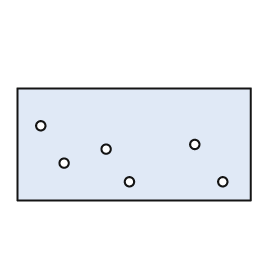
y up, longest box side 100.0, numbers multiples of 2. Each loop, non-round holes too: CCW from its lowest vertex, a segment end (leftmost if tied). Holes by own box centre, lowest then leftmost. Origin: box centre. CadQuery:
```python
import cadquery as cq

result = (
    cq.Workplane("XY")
    .moveTo(-50.0, -24.0)
    .lineTo(50.0, -24.0)
    .lineTo(50.0, 24.0)
    .lineTo(-50.0, 24.0)
    .close()
    .moveTo(-2.0, -16.0)
    .circle(2.0)
    .moveTo(38.0, -16.0)
    .circle(2.0)
    .moveTo(-30.0, -8.0)
    .circle(2.0)
    .moveTo(-12.0, -2.0)
    .circle(2.0)
    .moveTo(26.0, 0.0)
    .circle(2.0)
    .moveTo(-40.0, 8.0)
    .circle(2.0)
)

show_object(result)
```